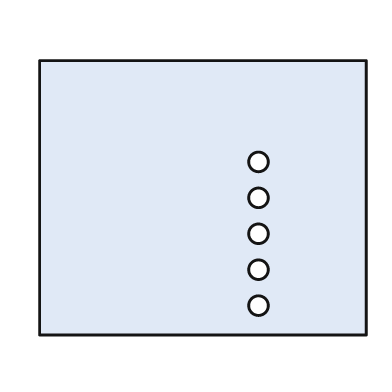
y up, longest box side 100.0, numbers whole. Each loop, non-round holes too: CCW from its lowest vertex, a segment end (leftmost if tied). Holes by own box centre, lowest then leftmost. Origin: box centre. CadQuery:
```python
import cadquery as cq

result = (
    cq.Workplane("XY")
    .moveTo(-50.0, -42.0)
    .lineTo(50.0, -42.0)
    .lineTo(50.0, 42.0)
    .lineTo(-50.0, 42.0)
    .close()
    .moveTo(17.0, -33.0)
    .circle(3.0)
    .moveTo(17.0, -22.0)
    .circle(3.0)
    .moveTo(17.0, -11.0)
    .circle(3.0)
    .moveTo(17.0, 0.0)
    .circle(3.0)
    .moveTo(17.0, 11.0)
    .circle(3.0)
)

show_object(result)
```